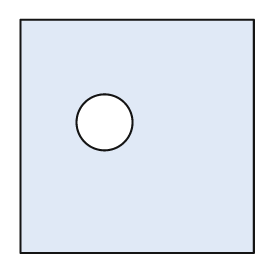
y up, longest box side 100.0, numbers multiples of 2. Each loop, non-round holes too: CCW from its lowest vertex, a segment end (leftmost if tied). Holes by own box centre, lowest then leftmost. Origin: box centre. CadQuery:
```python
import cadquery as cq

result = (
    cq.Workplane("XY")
    .moveTo(-50.0, -50.0)
    .lineTo(50.0, -50.0)
    .lineTo(50.0, 50.0)
    .lineTo(-50.0, 50.0)
    .close()
    .moveTo(-14.0, 6.0)
    .circle(12.0)
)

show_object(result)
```